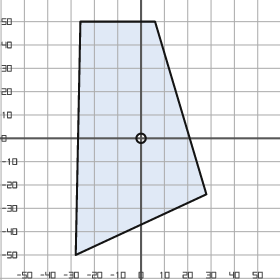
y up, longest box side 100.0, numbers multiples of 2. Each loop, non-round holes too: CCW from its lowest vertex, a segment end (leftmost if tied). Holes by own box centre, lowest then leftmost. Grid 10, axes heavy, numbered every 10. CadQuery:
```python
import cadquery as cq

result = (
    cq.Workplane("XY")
    .moveTo(-28.0, -50.0)
    .lineTo(28.0, -24.0)
    .lineTo(6.0, 50.0)
    .lineTo(-26.0, 50.0)
    .close()
    .moveTo(0.0, 0.0)
    .circle(2.0)
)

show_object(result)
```